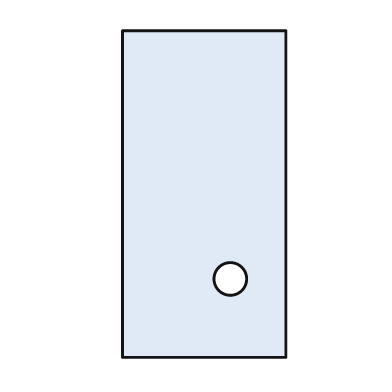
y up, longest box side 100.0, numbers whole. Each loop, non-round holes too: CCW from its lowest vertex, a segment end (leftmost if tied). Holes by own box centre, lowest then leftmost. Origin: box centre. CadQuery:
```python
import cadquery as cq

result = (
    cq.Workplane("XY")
    .moveTo(-25.0, -50.0)
    .lineTo(25.0, -50.0)
    .lineTo(25.0, 50.0)
    .lineTo(-25.0, 50.0)
    .close()
    .moveTo(8.0, -26.0)
    .circle(5.0)
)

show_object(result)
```